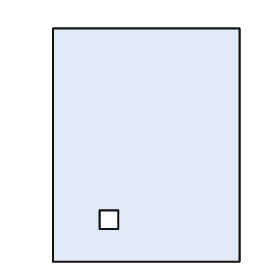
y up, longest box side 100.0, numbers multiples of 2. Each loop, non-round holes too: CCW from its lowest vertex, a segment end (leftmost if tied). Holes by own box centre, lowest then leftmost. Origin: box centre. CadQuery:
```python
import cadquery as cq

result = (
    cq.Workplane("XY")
    .moveTo(-40.0, -50.0)
    .lineTo(40.0, -50.0)
    .lineTo(40.0, 50.0)
    .lineTo(-40.0, 50.0)
    .close()
    .moveTo(-20.0, -36.0)
    .lineTo(-12.0, -36.0)
    .lineTo(-12.0, -28.0)
    .lineTo(-20.0, -28.0)
    .close()
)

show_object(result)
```